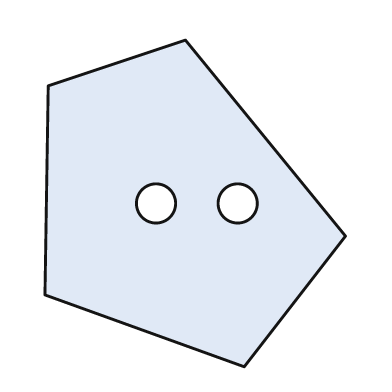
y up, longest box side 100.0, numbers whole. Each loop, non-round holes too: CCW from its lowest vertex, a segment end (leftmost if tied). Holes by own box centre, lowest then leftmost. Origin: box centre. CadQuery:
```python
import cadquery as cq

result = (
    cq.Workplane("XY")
    .moveTo(15.0, -50.0)
    .lineTo(46.0, -10.0)
    .lineTo(-3.0, 50.0)
    .lineTo(-45.0, 36.0)
    .lineTo(-46.0, -28.0)
    .close()
    .moveTo(-12.0, 0.0)
    .circle(6.0)
    .moveTo(13.0, 0.0)
    .circle(6.0)
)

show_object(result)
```